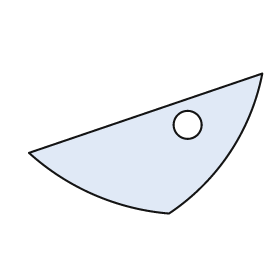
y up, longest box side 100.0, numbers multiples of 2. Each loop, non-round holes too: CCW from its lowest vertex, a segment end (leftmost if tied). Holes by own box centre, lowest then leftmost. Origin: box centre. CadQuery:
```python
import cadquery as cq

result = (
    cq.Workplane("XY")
    .moveTo(10.0, -30.0)
    .threePointArc((36.0, -4.0), (50.0, 30.0))
    .lineTo(-50.0, -4.0)
    .threePointArc((-22.0, -22.0), (10.0, -30.0))
    .close()
    .moveTo(18.0, 8.0)
    .circle(6.0)
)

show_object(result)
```